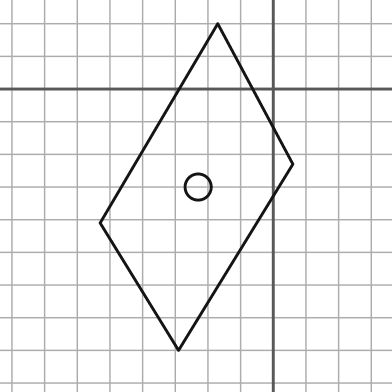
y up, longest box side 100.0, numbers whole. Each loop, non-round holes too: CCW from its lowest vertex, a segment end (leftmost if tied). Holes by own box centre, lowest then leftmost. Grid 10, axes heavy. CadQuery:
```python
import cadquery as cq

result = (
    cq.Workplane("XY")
    .moveTo(-29.0, -80.0)
    .lineTo(6.0, -23.0)
    .lineTo(-17.0, 20.0)
    .lineTo(-53.0, -41.0)
    .close()
    .moveTo(-23.0, -30.0)
    .circle(4.0)
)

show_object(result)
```